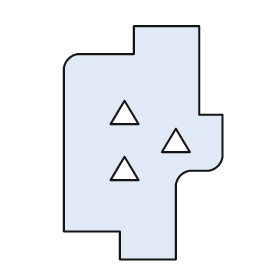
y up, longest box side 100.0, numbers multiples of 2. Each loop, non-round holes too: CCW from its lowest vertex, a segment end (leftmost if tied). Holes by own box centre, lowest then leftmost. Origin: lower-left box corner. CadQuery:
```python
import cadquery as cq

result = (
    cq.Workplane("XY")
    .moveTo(24.0, 0.0)
    .lineTo(48.0, 0.0)
    .lineTo(48.0, 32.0)
    .threePointArc((50.0, 36.0), (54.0, 38.0))
    .lineTo(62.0, 38.0)
    .threePointArc((66.0, 40.0), (68.0, 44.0))
    .lineTo(68.0, 62.0)
    .lineTo(58.0, 62.0)
    .lineTo(58.0, 100.0)
    .lineTo(30.0, 100.0)
    .lineTo(30.0, 88.0)
    .lineTo(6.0, 88.0)
    .threePointArc((2.0, 86.0), (0.0, 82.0))
    .lineTo(0.0, 12.0)
    .lineTo(24.0, 12.0)
    .close()
    .moveTo(20.0, 34.0)
    .lineTo(32.0, 34.0)
    .lineTo(26.0, 44.0)
    .close()
    .moveTo(42.0, 46.0)
    .lineTo(54.0, 46.0)
    .lineTo(48.0, 56.0)
    .close()
    .moveTo(20.0, 58.0)
    .lineTo(32.0, 58.0)
    .lineTo(26.0, 68.0)
    .close()
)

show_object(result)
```